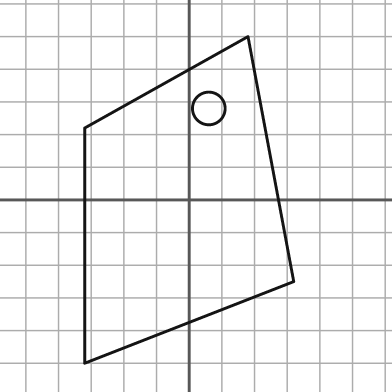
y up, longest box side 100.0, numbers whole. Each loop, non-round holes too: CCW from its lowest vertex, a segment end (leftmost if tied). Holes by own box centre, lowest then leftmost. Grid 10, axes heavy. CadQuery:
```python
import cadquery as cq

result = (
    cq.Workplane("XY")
    .moveTo(-32.0, -50.0)
    .lineTo(32.0, -25.0)
    .lineTo(18.0, 50.0)
    .lineTo(-32.0, 22.0)
    .close()
    .moveTo(6.0, 28.0)
    .circle(5.0)
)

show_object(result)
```